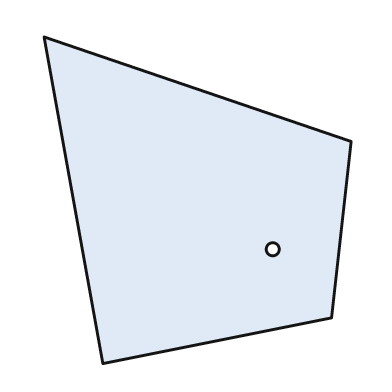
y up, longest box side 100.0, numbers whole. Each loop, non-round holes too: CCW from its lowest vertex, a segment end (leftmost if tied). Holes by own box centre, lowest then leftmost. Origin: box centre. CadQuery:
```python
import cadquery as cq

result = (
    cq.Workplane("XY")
    .moveTo(-29.0, -50.0)
    .lineTo(41.0, -36.0)
    .lineTo(47.0, 18.0)
    .lineTo(-47.0, 50.0)
    .close()
    .moveTo(23.0, -15.0)
    .circle(2.0)
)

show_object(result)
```